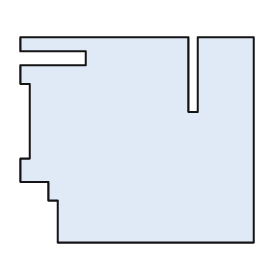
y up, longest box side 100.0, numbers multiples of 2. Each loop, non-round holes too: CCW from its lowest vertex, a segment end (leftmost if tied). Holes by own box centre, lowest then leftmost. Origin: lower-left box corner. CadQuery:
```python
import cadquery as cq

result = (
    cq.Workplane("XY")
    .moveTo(16.0, 0.0)
    .lineTo(100.0, 0.0)
    .lineTo(100.0, 88.0)
    .lineTo(76.0, 88.0)
    .lineTo(76.0, 56.0)
    .lineTo(72.0, 56.0)
    .lineTo(72.0, 88.0)
    .lineTo(0.0, 88.0)
    .lineTo(0.0, 82.0)
    .lineTo(28.0, 82.0)
    .lineTo(28.0, 76.0)
    .lineTo(0.0, 76.0)
    .lineTo(0.0, 68.0)
    .lineTo(4.0, 68.0)
    .lineTo(4.0, 36.0)
    .lineTo(0.0, 36.0)
    .lineTo(0.0, 26.0)
    .lineTo(12.0, 26.0)
    .lineTo(12.0, 18.0)
    .lineTo(16.0, 18.0)
    .close()
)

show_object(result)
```